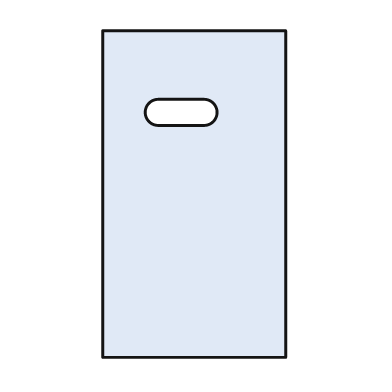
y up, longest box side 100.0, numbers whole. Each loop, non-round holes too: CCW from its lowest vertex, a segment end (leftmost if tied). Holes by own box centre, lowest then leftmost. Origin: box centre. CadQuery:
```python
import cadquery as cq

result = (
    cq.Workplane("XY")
    .moveTo(-28.0, -50.0)
    .lineTo(28.0, -50.0)
    .lineTo(28.0, 50.0)
    .lineTo(-28.0, 50.0)
    .close()
    .moveTo(-11.0, 21.0)
    .lineTo(3.0, 21.0)
    .threePointArc((7.0, 25.0), (3.0, 29.0))
    .lineTo(-11.0, 29.0)
    .threePointArc((-15.0, 25.0), (-11.0, 21.0))
    .close()
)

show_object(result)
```